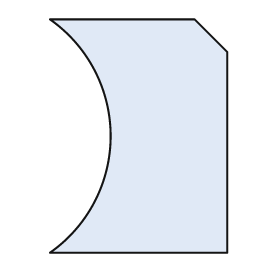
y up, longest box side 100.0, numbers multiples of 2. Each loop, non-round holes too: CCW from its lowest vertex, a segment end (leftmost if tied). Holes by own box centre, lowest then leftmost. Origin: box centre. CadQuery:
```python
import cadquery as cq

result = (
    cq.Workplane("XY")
    .moveTo(-38.0, -50.0)
    .lineTo(38.0, -50.0)
    .lineTo(38.0, 36.0)
    .lineTo(24.0, 50.0)
    .lineTo(-38.0, 50.0)
    .threePointArc((-12.0, 0.0), (-38.0, -50.0))
    .close()
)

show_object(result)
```